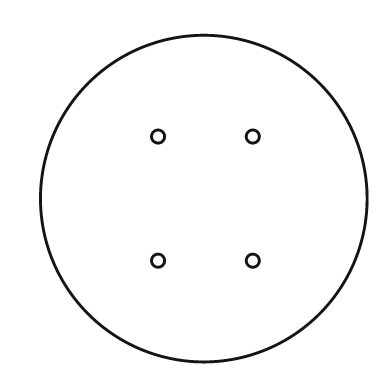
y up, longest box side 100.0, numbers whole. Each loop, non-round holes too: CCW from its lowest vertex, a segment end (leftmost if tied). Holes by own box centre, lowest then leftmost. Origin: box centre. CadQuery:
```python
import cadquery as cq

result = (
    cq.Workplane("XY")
    .moveTo(0.0, 0.0)
    .circle(50.0)
    .moveTo(-14.0, -19.0)
    .circle(2.0)
    .moveTo(15.0, -19.0)
    .circle(2.0)
    .moveTo(-14.0, 19.0)
    .circle(2.0)
    .moveTo(15.0, 19.0)
    .circle(2.0)
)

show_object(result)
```